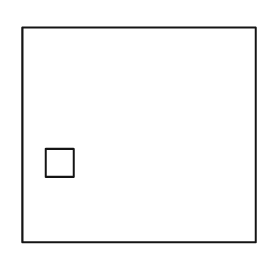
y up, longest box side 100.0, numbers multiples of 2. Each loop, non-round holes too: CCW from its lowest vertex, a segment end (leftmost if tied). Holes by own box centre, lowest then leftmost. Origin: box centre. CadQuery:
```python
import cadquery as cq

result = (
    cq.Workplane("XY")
    .moveTo(-50.0, -46.0)
    .lineTo(50.0, -46.0)
    .lineTo(50.0, 46.0)
    .lineTo(-50.0, 46.0)
    .close()
    .moveTo(-40.0, -18.0)
    .lineTo(-28.0, -18.0)
    .lineTo(-28.0, -6.0)
    .lineTo(-40.0, -6.0)
    .close()
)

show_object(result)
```